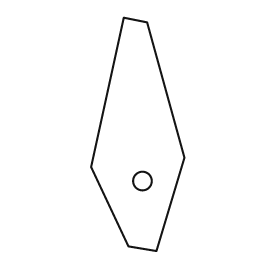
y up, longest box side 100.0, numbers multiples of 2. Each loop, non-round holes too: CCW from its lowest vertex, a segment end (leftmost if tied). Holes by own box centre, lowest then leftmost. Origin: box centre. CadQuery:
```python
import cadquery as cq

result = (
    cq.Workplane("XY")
    .moveTo(8.0, -50.0)
    .lineTo(20.0, -10.0)
    .lineTo(4.0, 48.0)
    .lineTo(-6.0, 50.0)
    .lineTo(-20.0, -14.0)
    .lineTo(-4.0, -48.0)
    .close()
    .moveTo(2.0, -20.0)
    .circle(4.0)
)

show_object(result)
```